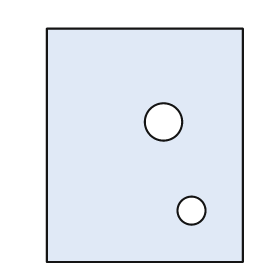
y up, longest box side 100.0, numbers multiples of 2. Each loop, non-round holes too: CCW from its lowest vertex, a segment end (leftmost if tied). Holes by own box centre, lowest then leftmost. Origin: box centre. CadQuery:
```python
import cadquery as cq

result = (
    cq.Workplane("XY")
    .moveTo(-42.0, -50.0)
    .lineTo(42.0, -50.0)
    .lineTo(42.0, 50.0)
    .lineTo(-42.0, 50.0)
    .close()
    .moveTo(20.0, -28.0)
    .circle(6.0)
    .moveTo(8.0, 10.0)
    .circle(8.0)
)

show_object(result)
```